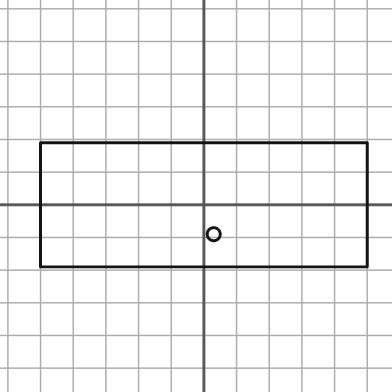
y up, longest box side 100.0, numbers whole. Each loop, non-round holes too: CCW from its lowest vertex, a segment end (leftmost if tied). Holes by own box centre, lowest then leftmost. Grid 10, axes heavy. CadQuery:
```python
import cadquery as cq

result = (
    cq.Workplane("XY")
    .moveTo(-50.0, -19.0)
    .lineTo(50.0, -19.0)
    .lineTo(50.0, 19.0)
    .lineTo(-50.0, 19.0)
    .close()
    .moveTo(3.0, -9.0)
    .circle(2.0)
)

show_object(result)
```